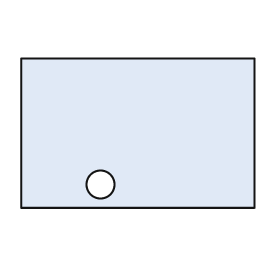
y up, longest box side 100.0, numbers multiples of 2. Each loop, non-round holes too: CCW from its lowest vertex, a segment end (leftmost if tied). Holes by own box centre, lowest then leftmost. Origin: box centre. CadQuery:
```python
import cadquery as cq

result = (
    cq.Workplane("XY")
    .moveTo(-50.0, -32.0)
    .lineTo(50.0, -32.0)
    .lineTo(50.0, 32.0)
    .lineTo(-50.0, 32.0)
    .close()
    .moveTo(-16.0, -22.0)
    .circle(6.0)
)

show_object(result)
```